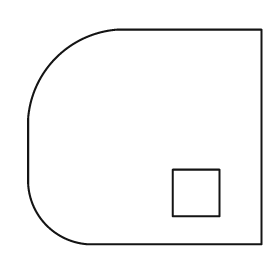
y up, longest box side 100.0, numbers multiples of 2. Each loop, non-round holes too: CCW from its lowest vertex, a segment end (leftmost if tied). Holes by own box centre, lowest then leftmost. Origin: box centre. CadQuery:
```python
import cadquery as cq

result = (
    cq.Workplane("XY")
    .moveTo(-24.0, -46.0)
    .lineTo(50.0, -46.0)
    .lineTo(50.0, 46.0)
    .lineTo(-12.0, 46.0)
    .threePointArc((-38.0, 34.0), (-50.0, 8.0))
    .lineTo(-50.0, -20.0)
    .threePointArc((-42.0, -38.0), (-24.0, -46.0))
    .close()
    .moveTo(12.0, -34.0)
    .lineTo(32.0, -34.0)
    .lineTo(32.0, -14.0)
    .lineTo(12.0, -14.0)
    .close()
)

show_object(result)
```